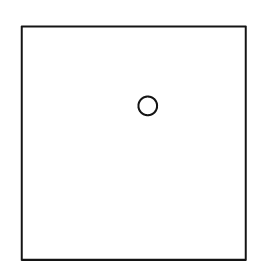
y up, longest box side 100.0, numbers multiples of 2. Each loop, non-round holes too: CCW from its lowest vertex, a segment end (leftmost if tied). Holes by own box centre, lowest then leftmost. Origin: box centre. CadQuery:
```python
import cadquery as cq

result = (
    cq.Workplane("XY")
    .moveTo(-48.0, -50.0)
    .lineTo(48.0, -50.0)
    .lineTo(48.0, 50.0)
    .lineTo(-48.0, 50.0)
    .close()
    .moveTo(6.0, 16.0)
    .circle(4.0)
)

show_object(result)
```